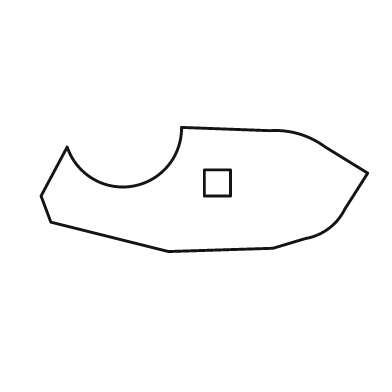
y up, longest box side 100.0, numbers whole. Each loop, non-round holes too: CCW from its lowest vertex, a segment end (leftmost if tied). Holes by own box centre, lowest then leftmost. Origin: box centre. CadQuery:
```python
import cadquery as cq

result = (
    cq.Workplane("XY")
    .moveTo(-11.0, -19.0)
    .lineTo(21.0, -18.0)
    .lineTo(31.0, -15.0)
    .threePointArc((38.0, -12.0), (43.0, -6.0))
    .lineTo(50.0, 5.0)
    .lineTo(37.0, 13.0)
    .threePointArc((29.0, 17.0), (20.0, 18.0))
    .lineTo(-7.0, 19.0)
    .threePointArc((-22.0, 1.0), (-42.0, 13.0))
    .lineTo(-50.0, -2.0)
    .lineTo(-47.0, -10.0)
    .close()
    .moveTo(0.0, -2.0)
    .lineTo(8.0, -2.0)
    .lineTo(8.0, 6.0)
    .lineTo(0.0, 6.0)
    .close()
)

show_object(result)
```